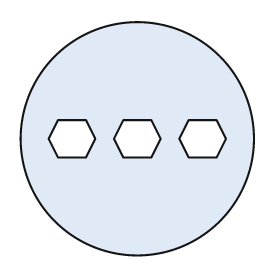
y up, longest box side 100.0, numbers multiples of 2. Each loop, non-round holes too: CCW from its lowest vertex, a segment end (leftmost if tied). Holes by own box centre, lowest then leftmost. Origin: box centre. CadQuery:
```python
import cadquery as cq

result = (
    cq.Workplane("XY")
    .moveTo(0.0, 0.0)
    .circle(50.0)
    .moveTo(-34.0, -8.0)
    .lineTo(-22.0, -8.0)
    .lineTo(-18.0, 0.0)
    .lineTo(-22.0, 8.0)
    .lineTo(-34.0, 8.0)
    .lineTo(-38.0, 0.0)
    .close()
    .moveTo(-6.0, -8.0)
    .lineTo(6.0, -8.0)
    .lineTo(10.0, 0.0)
    .lineTo(6.0, 8.0)
    .lineTo(-6.0, 8.0)
    .lineTo(-10.0, 0.0)
    .close()
    .moveTo(22.0, -8.0)
    .lineTo(34.0, -8.0)
    .lineTo(38.0, 0.0)
    .lineTo(34.0, 8.0)
    .lineTo(22.0, 8.0)
    .lineTo(18.0, 0.0)
    .close()
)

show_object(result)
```